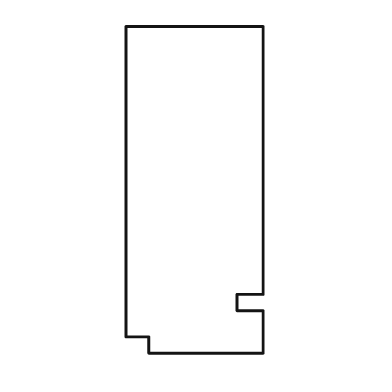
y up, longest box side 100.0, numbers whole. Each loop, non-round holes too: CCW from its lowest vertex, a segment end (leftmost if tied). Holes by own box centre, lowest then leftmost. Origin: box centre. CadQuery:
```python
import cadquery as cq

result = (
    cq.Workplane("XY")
    .moveTo(-14.0, -50.0)
    .lineTo(21.0, -50.0)
    .lineTo(21.0, -37.0)
    .lineTo(13.0, -37.0)
    .lineTo(13.0, -32.0)
    .lineTo(21.0, -32.0)
    .lineTo(21.0, 50.0)
    .lineTo(-21.0, 50.0)
    .lineTo(-21.0, -45.0)
    .lineTo(-14.0, -45.0)
    .close()
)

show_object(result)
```